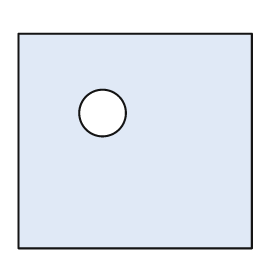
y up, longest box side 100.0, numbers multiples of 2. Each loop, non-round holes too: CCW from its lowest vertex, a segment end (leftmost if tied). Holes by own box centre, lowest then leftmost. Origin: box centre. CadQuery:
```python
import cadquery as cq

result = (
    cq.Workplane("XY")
    .moveTo(-50.0, -46.0)
    .lineTo(50.0, -46.0)
    .lineTo(50.0, 46.0)
    .lineTo(-50.0, 46.0)
    .close()
    .moveTo(-14.0, 12.0)
    .circle(10.0)
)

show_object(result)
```